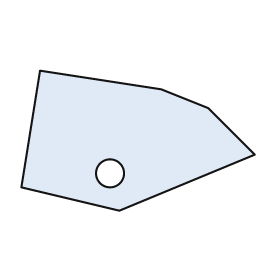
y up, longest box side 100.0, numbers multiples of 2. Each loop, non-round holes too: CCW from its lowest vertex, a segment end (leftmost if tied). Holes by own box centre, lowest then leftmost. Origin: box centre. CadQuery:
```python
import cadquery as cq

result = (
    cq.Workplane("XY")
    .moveTo(-8.0, -30.0)
    .lineTo(50.0, -6.0)
    .lineTo(30.0, 14.0)
    .lineTo(10.0, 22.0)
    .lineTo(-42.0, 30.0)
    .lineTo(-50.0, -20.0)
    .close()
    .moveTo(-12.0, -14.0)
    .circle(6.0)
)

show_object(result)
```